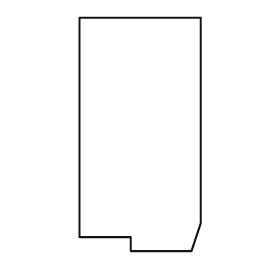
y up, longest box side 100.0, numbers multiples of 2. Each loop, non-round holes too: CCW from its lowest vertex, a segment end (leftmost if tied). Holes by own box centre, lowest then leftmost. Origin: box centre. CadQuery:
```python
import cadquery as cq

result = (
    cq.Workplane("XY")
    .moveTo(-4.0, -50.0)
    .lineTo(22.0, -50.0)
    .lineTo(26.0, -38.0)
    .lineTo(26.0, 50.0)
    .lineTo(-26.0, 50.0)
    .lineTo(-26.0, -44.0)
    .lineTo(-4.0, -44.0)
    .close()
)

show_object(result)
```